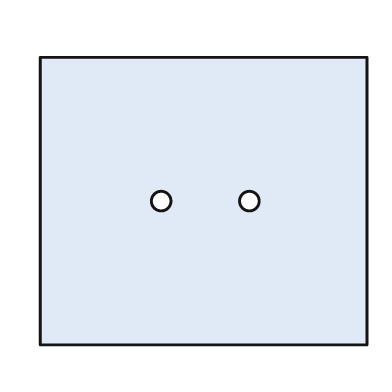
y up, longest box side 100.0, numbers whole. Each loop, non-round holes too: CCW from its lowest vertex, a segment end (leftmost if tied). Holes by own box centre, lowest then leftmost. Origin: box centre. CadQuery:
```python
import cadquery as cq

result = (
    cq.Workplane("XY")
    .moveTo(-50.0, -44.0)
    .lineTo(50.0, -44.0)
    .lineTo(50.0, 44.0)
    .lineTo(-50.0, 44.0)
    .close()
    .moveTo(-13.0, 0.0)
    .circle(3.0)
    .moveTo(14.0, 0.0)
    .circle(3.0)
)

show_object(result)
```